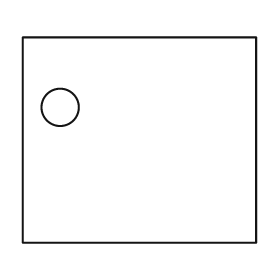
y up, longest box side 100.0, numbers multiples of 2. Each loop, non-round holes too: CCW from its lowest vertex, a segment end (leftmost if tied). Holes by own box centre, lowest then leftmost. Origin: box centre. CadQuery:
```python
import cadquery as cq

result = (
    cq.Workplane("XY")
    .moveTo(-50.0, -44.0)
    .lineTo(50.0, -44.0)
    .lineTo(50.0, 44.0)
    .lineTo(-50.0, 44.0)
    .close()
    .moveTo(-34.0, 14.0)
    .circle(8.0)
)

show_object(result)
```